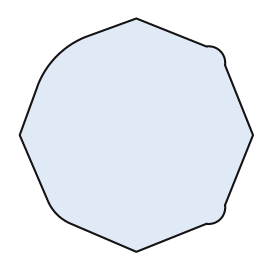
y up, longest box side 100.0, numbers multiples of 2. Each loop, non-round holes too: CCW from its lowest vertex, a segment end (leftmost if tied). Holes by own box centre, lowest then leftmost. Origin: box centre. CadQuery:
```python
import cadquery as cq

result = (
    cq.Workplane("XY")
    .moveTo(0.0, -50.0)
    .lineTo(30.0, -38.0)
    .threePointArc((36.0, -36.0), (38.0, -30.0))
    .lineTo(50.0, 0.0)
    .lineTo(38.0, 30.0)
    .threePointArc((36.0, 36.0), (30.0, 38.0))
    .lineTo(0.0, 50.0)
    .lineTo(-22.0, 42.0)
    .threePointArc((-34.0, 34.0), (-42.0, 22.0))
    .lineTo(-50.0, 0.0)
    .lineTo(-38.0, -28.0)
    .threePointArc((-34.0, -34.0), (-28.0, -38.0))
    .close()
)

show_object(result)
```